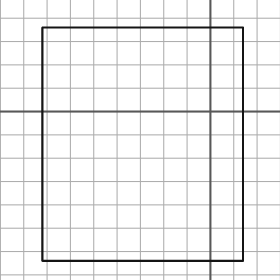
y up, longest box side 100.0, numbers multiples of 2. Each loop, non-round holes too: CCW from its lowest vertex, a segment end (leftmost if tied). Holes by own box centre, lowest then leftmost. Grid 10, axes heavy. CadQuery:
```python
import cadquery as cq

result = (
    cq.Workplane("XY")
    .moveTo(-72.0, -64.0)
    .lineTo(14.0, -64.0)
    .lineTo(14.0, 36.0)
    .lineTo(-72.0, 36.0)
    .close()
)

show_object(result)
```